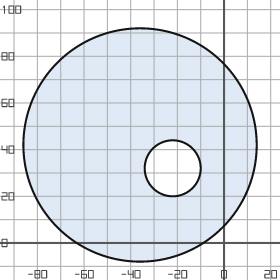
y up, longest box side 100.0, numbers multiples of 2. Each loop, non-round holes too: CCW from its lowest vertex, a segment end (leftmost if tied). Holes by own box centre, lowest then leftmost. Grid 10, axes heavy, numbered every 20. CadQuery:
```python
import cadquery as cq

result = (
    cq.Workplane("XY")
    .moveTo(-36.0, 42.0)
    .circle(50.0)
    .moveTo(-22.0, 32.0)
    .circle(12.0)
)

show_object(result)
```